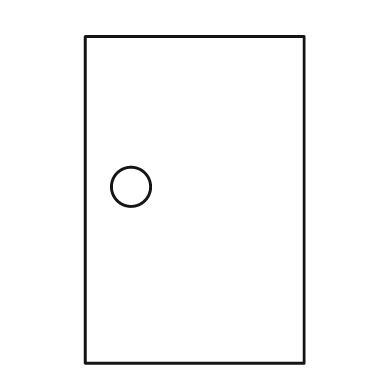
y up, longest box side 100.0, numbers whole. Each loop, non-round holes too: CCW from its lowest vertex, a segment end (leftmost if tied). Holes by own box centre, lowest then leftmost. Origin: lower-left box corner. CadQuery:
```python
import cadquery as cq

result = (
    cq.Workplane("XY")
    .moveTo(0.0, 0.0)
    .lineTo(67.0, 0.0)
    .lineTo(67.0, 100.0)
    .lineTo(0.0, 100.0)
    .close()
    .moveTo(14.0, 54.0)
    .circle(6.0)
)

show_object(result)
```